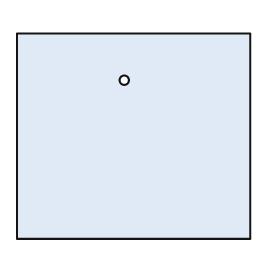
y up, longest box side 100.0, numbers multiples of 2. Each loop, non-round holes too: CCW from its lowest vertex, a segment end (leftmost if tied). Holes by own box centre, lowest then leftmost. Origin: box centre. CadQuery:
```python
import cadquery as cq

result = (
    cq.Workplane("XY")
    .moveTo(-50.0, -44.0)
    .lineTo(50.0, -44.0)
    .lineTo(50.0, 44.0)
    .lineTo(-50.0, 44.0)
    .close()
    .moveTo(-4.0, 24.0)
    .circle(2.0)
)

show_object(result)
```